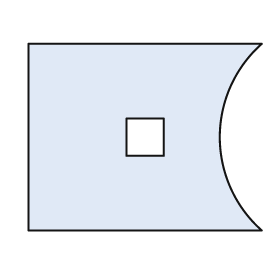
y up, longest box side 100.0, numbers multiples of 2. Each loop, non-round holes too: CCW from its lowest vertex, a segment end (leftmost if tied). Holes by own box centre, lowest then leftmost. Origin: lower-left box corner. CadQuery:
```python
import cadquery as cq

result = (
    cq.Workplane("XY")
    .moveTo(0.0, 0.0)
    .lineTo(100.0, 0.0)
    .threePointArc((82.0, 40.0), (100.0, 80.0))
    .lineTo(0.0, 80.0)
    .close()
    .moveTo(42.0, 32.0)
    .lineTo(58.0, 32.0)
    .lineTo(58.0, 48.0)
    .lineTo(42.0, 48.0)
    .close()
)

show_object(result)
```